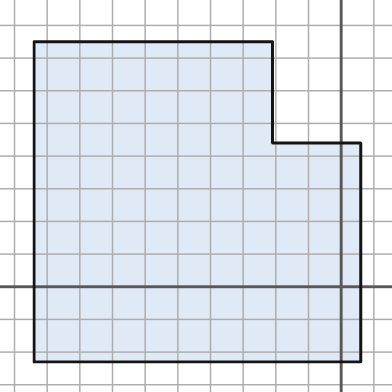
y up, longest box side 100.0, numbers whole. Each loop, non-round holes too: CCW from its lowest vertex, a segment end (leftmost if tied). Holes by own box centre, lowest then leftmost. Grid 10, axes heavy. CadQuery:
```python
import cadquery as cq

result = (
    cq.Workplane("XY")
    .moveTo(-94.0, -23.0)
    .lineTo(6.0, -23.0)
    .lineTo(6.0, 44.0)
    .lineTo(-21.0, 44.0)
    .lineTo(-21.0, 75.0)
    .lineTo(-94.0, 75.0)
    .close()
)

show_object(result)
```